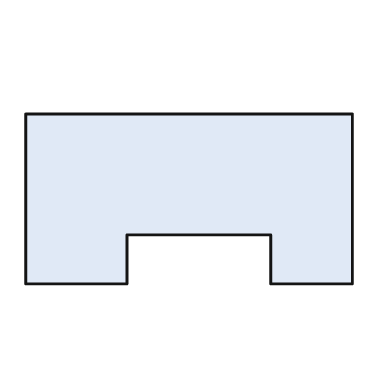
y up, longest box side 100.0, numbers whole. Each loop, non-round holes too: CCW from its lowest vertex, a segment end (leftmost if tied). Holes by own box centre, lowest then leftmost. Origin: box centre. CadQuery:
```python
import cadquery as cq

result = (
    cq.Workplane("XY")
    .moveTo(-50.0, -26.0)
    .lineTo(-19.0, -26.0)
    .lineTo(-19.0, -11.0)
    .lineTo(25.0, -11.0)
    .lineTo(25.0, -26.0)
    .lineTo(50.0, -26.0)
    .lineTo(50.0, 26.0)
    .lineTo(-50.0, 26.0)
    .close()
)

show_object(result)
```